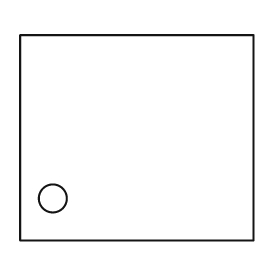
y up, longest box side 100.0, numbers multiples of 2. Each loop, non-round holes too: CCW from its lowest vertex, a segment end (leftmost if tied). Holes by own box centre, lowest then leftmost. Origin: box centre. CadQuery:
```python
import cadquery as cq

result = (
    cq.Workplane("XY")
    .moveTo(-50.0, -44.0)
    .lineTo(50.0, -44.0)
    .lineTo(50.0, 44.0)
    .lineTo(-50.0, 44.0)
    .close()
    .moveTo(-36.0, -26.0)
    .circle(6.0)
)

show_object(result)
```